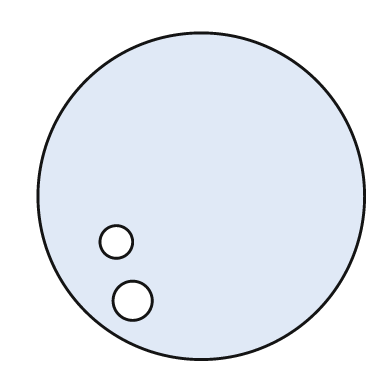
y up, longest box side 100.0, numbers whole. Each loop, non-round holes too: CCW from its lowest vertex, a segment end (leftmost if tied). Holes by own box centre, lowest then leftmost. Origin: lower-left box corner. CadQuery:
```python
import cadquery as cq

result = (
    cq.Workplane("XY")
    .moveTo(50.0, 50.0)
    .circle(50.0)
    .moveTo(29.0, 18.0)
    .circle(6.0)
    .moveTo(24.0, 36.0)
    .circle(5.0)
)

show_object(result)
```